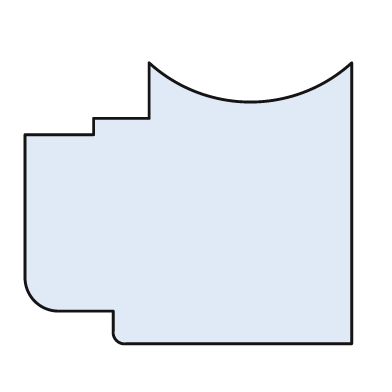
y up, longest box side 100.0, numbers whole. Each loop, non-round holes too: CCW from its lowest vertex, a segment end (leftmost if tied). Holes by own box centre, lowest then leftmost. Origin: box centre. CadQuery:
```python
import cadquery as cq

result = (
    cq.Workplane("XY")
    .moveTo(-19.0, -43.0)
    .lineTo(50.0, -43.0)
    .lineTo(50.0, 43.0)
    .threePointArc((19.0, 31.0), (-12.0, 43.0))
    .lineTo(-12.0, 26.0)
    .lineTo(-29.0, 26.0)
    .lineTo(-29.0, 21.0)
    .lineTo(-50.0, 21.0)
    .lineTo(-50.0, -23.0)
    .threePointArc((-47.0, -30.0), (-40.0, -33.0))
    .lineTo(-23.0, -33.0)
    .lineTo(-23.0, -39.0)
    .threePointArc((-22.0, -42.0), (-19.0, -43.0))
    .close()
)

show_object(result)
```